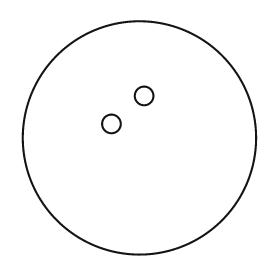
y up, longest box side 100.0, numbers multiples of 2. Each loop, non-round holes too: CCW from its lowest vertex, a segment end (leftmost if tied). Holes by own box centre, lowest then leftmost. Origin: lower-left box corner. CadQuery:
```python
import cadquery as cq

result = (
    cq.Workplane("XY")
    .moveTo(50.0, 50.0)
    .circle(50.0)
    .moveTo(38.0, 56.0)
    .circle(4.0)
    .moveTo(52.0, 68.0)
    .circle(4.0)
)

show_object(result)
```